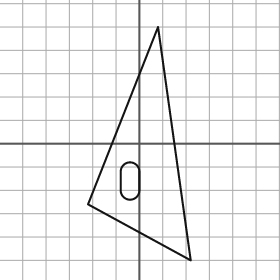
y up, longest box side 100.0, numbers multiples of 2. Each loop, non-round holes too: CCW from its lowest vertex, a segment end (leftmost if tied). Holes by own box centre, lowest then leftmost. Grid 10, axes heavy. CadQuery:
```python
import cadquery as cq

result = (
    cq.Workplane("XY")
    .moveTo(22.0, -50.0)
    .lineTo(8.0, 50.0)
    .lineTo(-22.0, -26.0)
    .close()
    .moveTo(-8.0, -20.0)
    .threePointArc((-4.0, -24.0), (0.0, -20.0))
    .lineTo(0.0, -12.0)
    .threePointArc((-4.0, -8.0), (-8.0, -12.0))
    .close()
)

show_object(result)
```